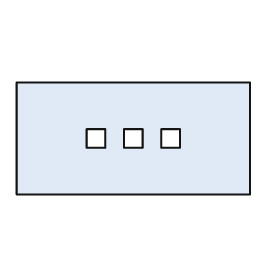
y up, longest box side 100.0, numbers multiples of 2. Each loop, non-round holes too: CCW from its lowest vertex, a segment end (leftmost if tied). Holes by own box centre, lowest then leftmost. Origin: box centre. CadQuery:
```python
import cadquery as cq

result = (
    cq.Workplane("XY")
    .moveTo(-50.0, -24.0)
    .lineTo(50.0, -24.0)
    .lineTo(50.0, 24.0)
    .lineTo(-50.0, 24.0)
    .close()
    .moveTo(-20.0, -4.0)
    .lineTo(-12.0, -4.0)
    .lineTo(-12.0, 4.0)
    .lineTo(-20.0, 4.0)
    .close()
    .moveTo(-4.0, -4.0)
    .lineTo(4.0, -4.0)
    .lineTo(4.0, 4.0)
    .lineTo(-4.0, 4.0)
    .close()
    .moveTo(12.0, -4.0)
    .lineTo(20.0, -4.0)
    .lineTo(20.0, 4.0)
    .lineTo(12.0, 4.0)
    .close()
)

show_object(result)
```